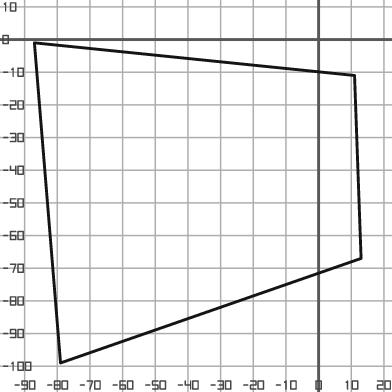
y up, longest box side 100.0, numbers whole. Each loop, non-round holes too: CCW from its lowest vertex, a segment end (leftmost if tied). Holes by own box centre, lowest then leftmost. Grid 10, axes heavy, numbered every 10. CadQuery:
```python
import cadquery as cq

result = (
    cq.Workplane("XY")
    .moveTo(-79.0, -99.0)
    .lineTo(13.0, -67.0)
    .lineTo(11.0, -11.0)
    .lineTo(-87.0, -1.0)
    .close()
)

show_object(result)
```